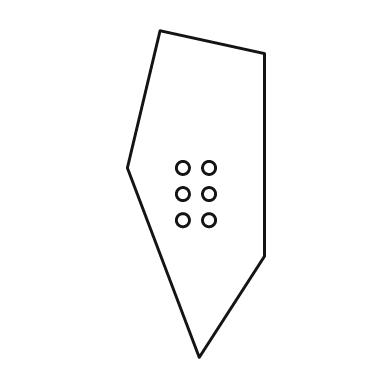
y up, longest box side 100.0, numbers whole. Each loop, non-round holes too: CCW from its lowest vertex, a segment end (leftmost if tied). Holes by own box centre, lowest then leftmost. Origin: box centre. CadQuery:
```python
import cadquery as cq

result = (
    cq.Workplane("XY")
    .moveTo(1.0, -50.0)
    .lineTo(21.0, -19.0)
    .lineTo(21.0, 43.0)
    .lineTo(-11.0, 50.0)
    .lineTo(-21.0, 8.0)
    .close()
    .moveTo(-4.0, -8.0)
    .circle(2.0)
    .moveTo(4.0, -8.0)
    .circle(2.0)
    .moveTo(-4.0, 0.0)
    .circle(2.0)
    .moveTo(4.0, 0.0)
    .circle(2.0)
    .moveTo(-4.0, 8.0)
    .circle(2.0)
    .moveTo(4.0, 8.0)
    .circle(2.0)
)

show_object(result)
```